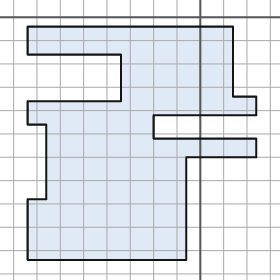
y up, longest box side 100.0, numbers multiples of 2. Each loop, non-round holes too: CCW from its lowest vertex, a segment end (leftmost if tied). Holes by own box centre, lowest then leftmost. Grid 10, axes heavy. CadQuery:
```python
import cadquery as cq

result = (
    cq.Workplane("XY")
    .moveTo(-74.0, -104.0)
    .lineTo(-6.0, -104.0)
    .lineTo(-6.0, -60.0)
    .lineTo(24.0, -60.0)
    .lineTo(24.0, -52.0)
    .lineTo(-20.0, -52.0)
    .lineTo(-20.0, -42.0)
    .lineTo(24.0, -42.0)
    .lineTo(24.0, -34.0)
    .lineTo(14.0, -34.0)
    .lineTo(14.0, -4.0)
    .lineTo(-74.0, -4.0)
    .lineTo(-74.0, -16.0)
    .lineTo(-34.0, -16.0)
    .lineTo(-34.0, -36.0)
    .lineTo(-74.0, -36.0)
    .lineTo(-74.0, -46.0)
    .lineTo(-66.0, -46.0)
    .lineTo(-66.0, -78.0)
    .lineTo(-74.0, -78.0)
    .close()
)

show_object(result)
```